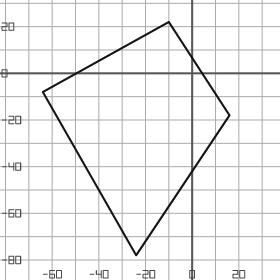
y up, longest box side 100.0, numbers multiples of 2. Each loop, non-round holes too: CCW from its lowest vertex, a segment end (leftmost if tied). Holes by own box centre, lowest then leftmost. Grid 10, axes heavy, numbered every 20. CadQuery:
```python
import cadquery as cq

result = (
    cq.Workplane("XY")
    .moveTo(-24.0, -78.0)
    .lineTo(16.0, -18.0)
    .lineTo(-10.0, 22.0)
    .lineTo(-64.0, -8.0)
    .close()
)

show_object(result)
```